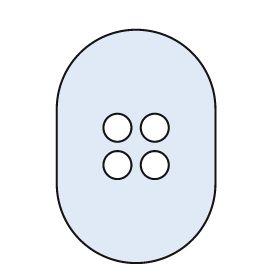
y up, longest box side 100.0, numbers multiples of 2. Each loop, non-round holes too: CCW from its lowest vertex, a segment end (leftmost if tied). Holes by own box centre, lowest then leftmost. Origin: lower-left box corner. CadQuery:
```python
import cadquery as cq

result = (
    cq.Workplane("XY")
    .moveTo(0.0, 34.0)
    .threePointArc((34.0, 0.0), (68.0, 34.0))
    .lineTo(68.0, 66.0)
    .threePointArc((34.0, 100.0), (0.0, 66.0))
    .close()
    .moveTo(26.0, 42.0)
    .circle(6.0)
    .moveTo(42.0, 42.0)
    .circle(6.0)
    .moveTo(26.0, 58.0)
    .circle(6.0)
    .moveTo(42.0, 58.0)
    .circle(6.0)
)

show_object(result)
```